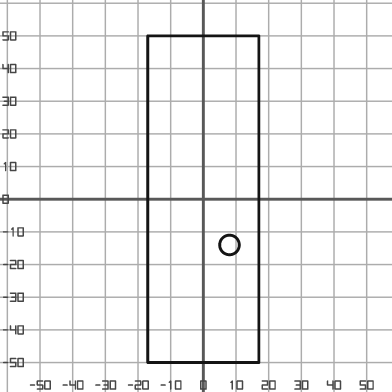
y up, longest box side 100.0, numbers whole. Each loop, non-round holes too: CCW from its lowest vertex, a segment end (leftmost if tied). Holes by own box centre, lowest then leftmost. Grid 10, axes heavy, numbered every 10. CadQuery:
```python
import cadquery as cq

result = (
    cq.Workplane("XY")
    .moveTo(-17.0, -50.0)
    .lineTo(17.0, -50.0)
    .lineTo(17.0, 50.0)
    .lineTo(-17.0, 50.0)
    .close()
    .moveTo(8.0, -14.0)
    .circle(3.0)
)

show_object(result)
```